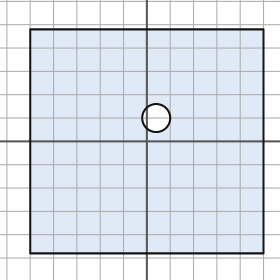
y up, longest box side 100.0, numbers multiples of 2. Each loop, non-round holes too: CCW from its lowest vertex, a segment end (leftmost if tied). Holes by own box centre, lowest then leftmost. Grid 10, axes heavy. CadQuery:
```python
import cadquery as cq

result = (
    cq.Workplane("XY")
    .moveTo(-50.0, -48.0)
    .lineTo(50.0, -48.0)
    .lineTo(50.0, 48.0)
    .lineTo(-50.0, 48.0)
    .close()
    .moveTo(4.0, 10.0)
    .circle(6.0)
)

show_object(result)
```